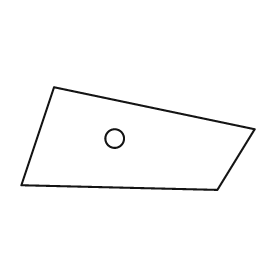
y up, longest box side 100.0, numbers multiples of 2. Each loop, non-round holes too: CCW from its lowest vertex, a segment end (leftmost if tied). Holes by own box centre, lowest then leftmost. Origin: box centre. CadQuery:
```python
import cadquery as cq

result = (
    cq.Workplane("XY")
    .moveTo(34.0, -22.0)
    .lineTo(50.0, 4.0)
    .lineTo(-36.0, 22.0)
    .lineTo(-50.0, -20.0)
    .close()
    .moveTo(-10.0, 0.0)
    .circle(4.0)
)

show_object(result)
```